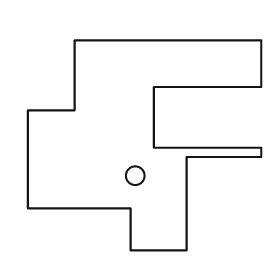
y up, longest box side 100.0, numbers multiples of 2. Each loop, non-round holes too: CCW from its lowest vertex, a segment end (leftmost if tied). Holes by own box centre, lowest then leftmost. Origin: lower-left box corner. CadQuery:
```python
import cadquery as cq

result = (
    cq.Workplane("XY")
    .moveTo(44.0, 0.0)
    .lineTo(68.0, 0.0)
    .lineTo(68.0, 40.0)
    .lineTo(100.0, 40.0)
    .lineTo(100.0, 44.0)
    .lineTo(54.0, 44.0)
    .lineTo(54.0, 70.0)
    .lineTo(100.0, 70.0)
    .lineTo(100.0, 90.0)
    .lineTo(20.0, 90.0)
    .lineTo(20.0, 60.0)
    .lineTo(0.0, 60.0)
    .lineTo(0.0, 18.0)
    .lineTo(44.0, 18.0)
    .close()
    .moveTo(46.0, 32.0)
    .circle(4.0)
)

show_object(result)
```